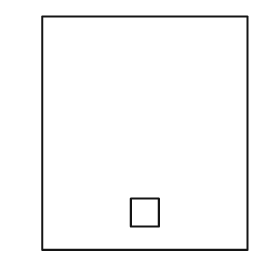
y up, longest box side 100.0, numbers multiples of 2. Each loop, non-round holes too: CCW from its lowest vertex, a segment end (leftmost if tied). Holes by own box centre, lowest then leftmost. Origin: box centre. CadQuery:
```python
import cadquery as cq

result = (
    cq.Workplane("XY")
    .moveTo(-44.0, -50.0)
    .lineTo(44.0, -50.0)
    .lineTo(44.0, 50.0)
    .lineTo(-44.0, 50.0)
    .close()
    .moveTo(-6.0, -40.0)
    .lineTo(6.0, -40.0)
    .lineTo(6.0, -28.0)
    .lineTo(-6.0, -28.0)
    .close()
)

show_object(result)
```